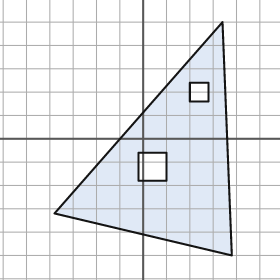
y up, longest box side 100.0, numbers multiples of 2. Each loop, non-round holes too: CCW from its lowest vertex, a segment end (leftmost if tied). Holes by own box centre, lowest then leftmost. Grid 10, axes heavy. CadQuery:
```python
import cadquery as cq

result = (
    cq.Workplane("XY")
    .moveTo(38.0, -50.0)
    .lineTo(34.0, 50.0)
    .lineTo(-38.0, -32.0)
    .close()
    .moveTo(-2.0, -18.0)
    .lineTo(10.0, -18.0)
    .lineTo(10.0, -6.0)
    .lineTo(-2.0, -6.0)
    .close()
    .moveTo(20.0, 16.0)
    .lineTo(28.0, 16.0)
    .lineTo(28.0, 24.0)
    .lineTo(20.0, 24.0)
    .close()
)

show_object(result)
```